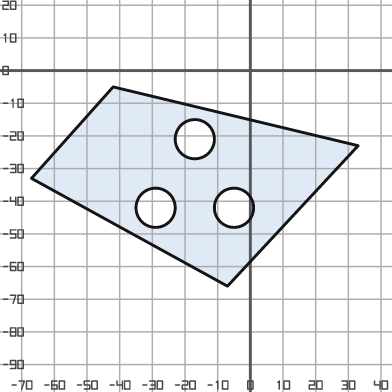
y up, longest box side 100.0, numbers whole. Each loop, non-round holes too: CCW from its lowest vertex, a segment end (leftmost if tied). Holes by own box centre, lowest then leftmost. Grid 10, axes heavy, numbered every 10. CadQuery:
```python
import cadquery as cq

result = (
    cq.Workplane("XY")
    .moveTo(-7.0, -66.0)
    .lineTo(33.0, -23.0)
    .lineTo(-42.0, -5.0)
    .lineTo(-67.0, -33.0)
    .close()
    .moveTo(-29.0, -42.0)
    .circle(6.0)
    .moveTo(-5.0, -42.0)
    .circle(6.0)
    .moveTo(-17.0, -21.0)
    .circle(6.0)
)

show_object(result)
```